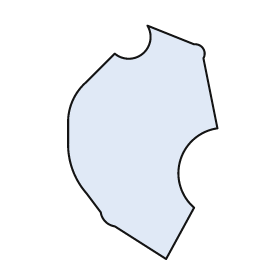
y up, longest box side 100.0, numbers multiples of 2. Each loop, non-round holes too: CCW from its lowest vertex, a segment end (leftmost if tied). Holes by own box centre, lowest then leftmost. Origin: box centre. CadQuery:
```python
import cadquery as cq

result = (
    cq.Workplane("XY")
    .moveTo(10.0, -50.0)
    .lineTo(22.0, -28.0)
    .threePointArc((16.0, -8.0), (32.0, 6.0))
    .lineTo(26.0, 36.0)
    .threePointArc((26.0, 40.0), (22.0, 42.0))
    .lineTo(2.0, 50.0)
    .threePointArc((0.0, 38.0), (-12.0, 38.0))
    .lineTo(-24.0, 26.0)
    .threePointArc((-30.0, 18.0), (-32.0, 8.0))
    .lineTo(-32.0, 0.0)
    .threePointArc((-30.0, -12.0), (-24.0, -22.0))
    .lineTo(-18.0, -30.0)
    .threePointArc((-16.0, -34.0), (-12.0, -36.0))
    .close()
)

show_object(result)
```